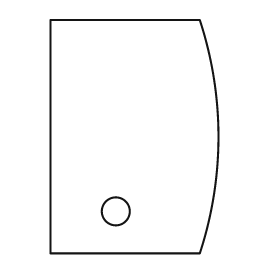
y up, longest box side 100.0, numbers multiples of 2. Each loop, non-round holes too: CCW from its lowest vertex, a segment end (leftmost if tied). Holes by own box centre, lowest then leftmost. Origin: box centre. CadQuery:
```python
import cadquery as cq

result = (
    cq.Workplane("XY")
    .moveTo(-36.0, -50.0)
    .lineTo(28.0, -50.0)
    .threePointArc((36.0, 0.0), (28.0, 50.0))
    .lineTo(-36.0, 50.0)
    .close()
    .moveTo(-8.0, -32.0)
    .circle(6.0)
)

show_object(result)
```